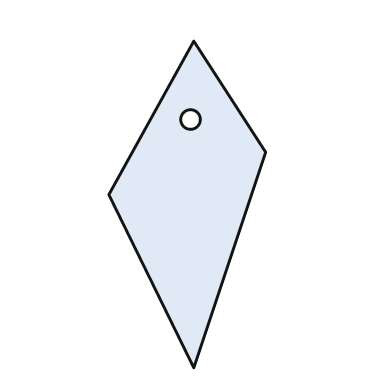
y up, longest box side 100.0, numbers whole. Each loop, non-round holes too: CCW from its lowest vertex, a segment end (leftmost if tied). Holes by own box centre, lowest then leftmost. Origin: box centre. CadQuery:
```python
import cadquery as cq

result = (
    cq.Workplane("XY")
    .moveTo(2.0, -50.0)
    .lineTo(24.0, 16.0)
    .lineTo(2.0, 50.0)
    .lineTo(-24.0, 3.0)
    .close()
    .moveTo(1.0, 26.0)
    .circle(3.0)
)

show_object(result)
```